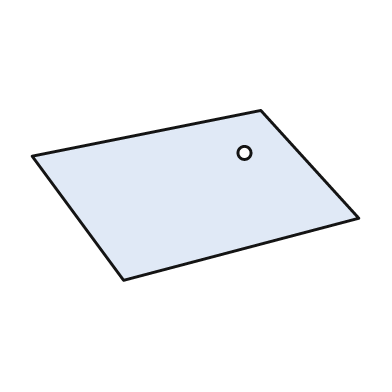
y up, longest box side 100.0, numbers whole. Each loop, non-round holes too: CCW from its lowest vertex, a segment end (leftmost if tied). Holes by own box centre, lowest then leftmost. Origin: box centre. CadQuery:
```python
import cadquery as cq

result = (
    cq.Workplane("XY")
    .moveTo(-22.0, -26.0)
    .lineTo(50.0, -7.0)
    .lineTo(20.0, 26.0)
    .lineTo(-50.0, 12.0)
    .close()
    .moveTo(15.0, 13.0)
    .circle(2.0)
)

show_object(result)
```